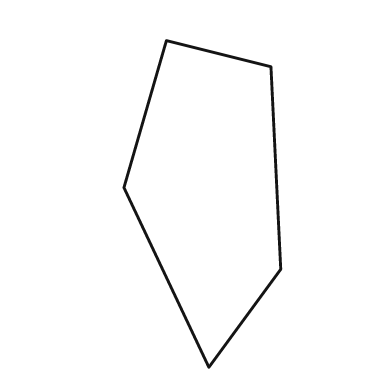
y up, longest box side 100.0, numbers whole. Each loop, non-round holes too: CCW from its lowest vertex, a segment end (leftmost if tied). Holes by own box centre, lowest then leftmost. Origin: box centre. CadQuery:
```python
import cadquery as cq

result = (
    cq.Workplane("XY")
    .moveTo(2.0, -50.0)
    .lineTo(24.0, -20.0)
    .lineTo(21.0, 42.0)
    .lineTo(-11.0, 50.0)
    .lineTo(-24.0, 5.0)
    .close()
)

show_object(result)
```